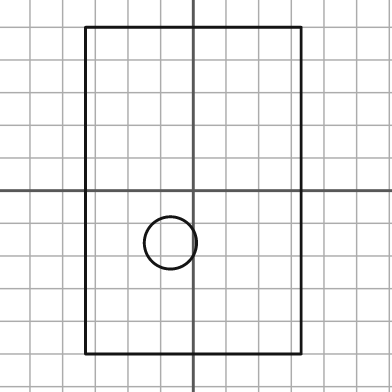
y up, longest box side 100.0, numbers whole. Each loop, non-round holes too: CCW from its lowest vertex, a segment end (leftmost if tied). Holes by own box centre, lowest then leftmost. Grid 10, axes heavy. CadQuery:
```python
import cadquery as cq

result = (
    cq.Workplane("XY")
    .moveTo(-33.0, -50.0)
    .lineTo(33.0, -50.0)
    .lineTo(33.0, 50.0)
    .lineTo(-33.0, 50.0)
    .close()
    .moveTo(-7.0, -16.0)
    .circle(8.0)
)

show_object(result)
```